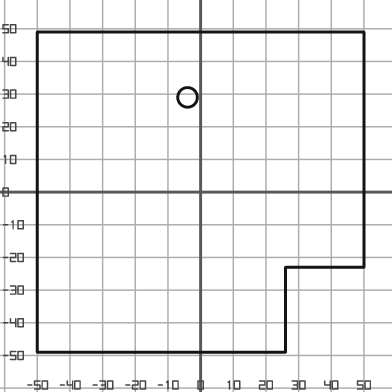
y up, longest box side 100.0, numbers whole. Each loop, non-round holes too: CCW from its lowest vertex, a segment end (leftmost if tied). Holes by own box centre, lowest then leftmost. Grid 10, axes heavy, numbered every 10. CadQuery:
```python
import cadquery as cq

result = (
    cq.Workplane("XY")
    .moveTo(-50.0, -49.0)
    .lineTo(26.0, -49.0)
    .lineTo(26.0, -23.0)
    .lineTo(50.0, -23.0)
    .lineTo(50.0, 49.0)
    .lineTo(-50.0, 49.0)
    .close()
    .moveTo(-4.0, 29.0)
    .circle(3.0)
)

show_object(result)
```